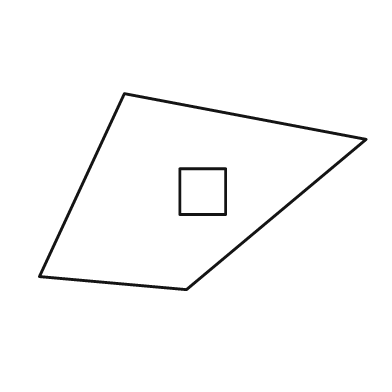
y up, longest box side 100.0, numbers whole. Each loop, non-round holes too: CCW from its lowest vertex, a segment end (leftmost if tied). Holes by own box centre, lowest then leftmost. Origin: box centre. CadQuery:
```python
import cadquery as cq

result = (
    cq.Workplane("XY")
    .moveTo(-5.0, -30.0)
    .lineTo(50.0, 16.0)
    .lineTo(-24.0, 30.0)
    .lineTo(-50.0, -26.0)
    .close()
    .moveTo(-7.0, -7.0)
    .lineTo(7.0, -7.0)
    .lineTo(7.0, 7.0)
    .lineTo(-7.0, 7.0)
    .close()
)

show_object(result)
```